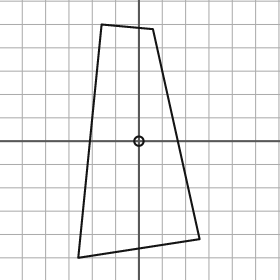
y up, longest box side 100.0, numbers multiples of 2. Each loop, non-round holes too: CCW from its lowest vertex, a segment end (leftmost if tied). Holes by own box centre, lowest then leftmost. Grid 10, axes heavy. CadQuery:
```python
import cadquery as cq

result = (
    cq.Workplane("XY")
    .moveTo(-26.0, -50.0)
    .lineTo(26.0, -42.0)
    .lineTo(6.0, 48.0)
    .lineTo(-16.0, 50.0)
    .close()
    .moveTo(0.0, 0.0)
    .circle(2.0)
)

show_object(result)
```